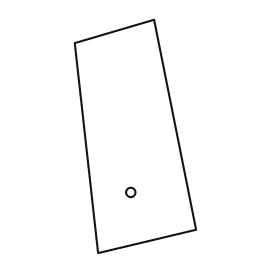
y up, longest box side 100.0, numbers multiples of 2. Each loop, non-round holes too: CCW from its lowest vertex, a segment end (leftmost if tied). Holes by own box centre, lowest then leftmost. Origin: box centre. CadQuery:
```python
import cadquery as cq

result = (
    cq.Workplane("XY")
    .moveTo(-16.0, -50.0)
    .lineTo(26.0, -40.0)
    .lineTo(8.0, 50.0)
    .lineTo(-26.0, 40.0)
    .close()
    .moveTo(-2.0, -24.0)
    .circle(2.0)
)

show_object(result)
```